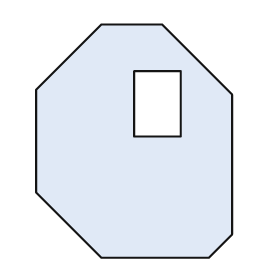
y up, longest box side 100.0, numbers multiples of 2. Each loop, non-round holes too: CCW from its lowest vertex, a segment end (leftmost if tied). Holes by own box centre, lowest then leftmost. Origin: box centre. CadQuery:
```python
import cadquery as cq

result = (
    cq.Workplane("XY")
    .moveTo(-14.0, -50.0)
    .lineTo(32.0, -50.0)
    .lineTo(42.0, -40.0)
    .lineTo(42.0, 20.0)
    .lineTo(12.0, 50.0)
    .lineTo(-14.0, 50.0)
    .lineTo(-42.0, 22.0)
    .lineTo(-42.0, -22.0)
    .close()
    .moveTo(0.0, 2.0)
    .lineTo(20.0, 2.0)
    .lineTo(20.0, 30.0)
    .lineTo(0.0, 30.0)
    .close()
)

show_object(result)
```